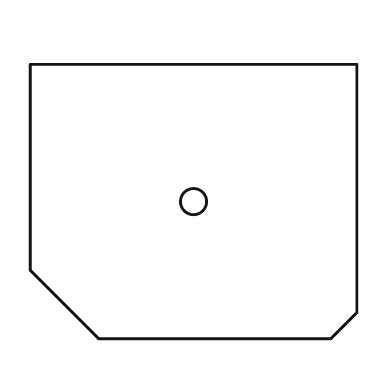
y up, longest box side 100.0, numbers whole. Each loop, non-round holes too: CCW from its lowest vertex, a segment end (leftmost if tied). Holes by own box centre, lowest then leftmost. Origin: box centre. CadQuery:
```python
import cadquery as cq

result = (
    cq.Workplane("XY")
    .moveTo(-29.0, -42.0)
    .lineTo(42.0, -42.0)
    .lineTo(50.0, -34.0)
    .lineTo(50.0, 42.0)
    .lineTo(-50.0, 42.0)
    .lineTo(-50.0, -21.0)
    .close()
    .moveTo(0.0, 0.0)
    .circle(4.0)
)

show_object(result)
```